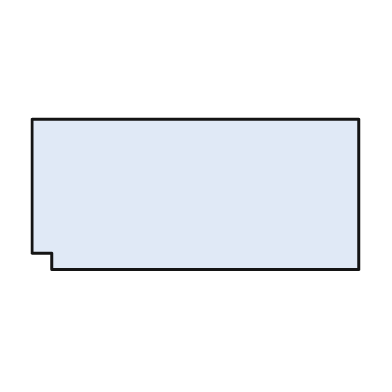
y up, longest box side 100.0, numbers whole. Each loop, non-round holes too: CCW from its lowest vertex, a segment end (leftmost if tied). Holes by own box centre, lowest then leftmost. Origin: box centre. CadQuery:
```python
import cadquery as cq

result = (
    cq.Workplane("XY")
    .moveTo(-44.0, -23.0)
    .lineTo(50.0, -23.0)
    .lineTo(50.0, 23.0)
    .lineTo(-50.0, 23.0)
    .lineTo(-50.0, -18.0)
    .lineTo(-44.0, -18.0)
    .close()
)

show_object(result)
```